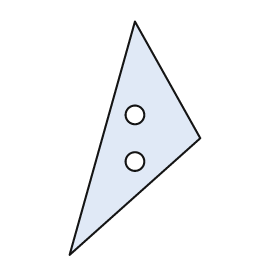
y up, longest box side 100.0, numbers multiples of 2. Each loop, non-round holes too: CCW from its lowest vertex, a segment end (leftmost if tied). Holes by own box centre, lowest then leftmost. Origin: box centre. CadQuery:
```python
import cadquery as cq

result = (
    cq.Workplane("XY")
    .moveTo(-28.0, -50.0)
    .lineTo(28.0, 0.0)
    .lineTo(0.0, 50.0)
    .close()
    .moveTo(0.0, -10.0)
    .circle(4.0)
    .moveTo(0.0, 10.0)
    .circle(4.0)
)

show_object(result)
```